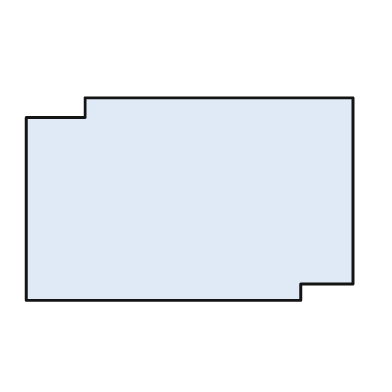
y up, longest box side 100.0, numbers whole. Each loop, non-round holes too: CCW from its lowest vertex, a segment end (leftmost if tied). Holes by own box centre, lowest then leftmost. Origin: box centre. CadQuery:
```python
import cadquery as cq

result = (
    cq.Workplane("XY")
    .moveTo(-50.0, -31.0)
    .lineTo(34.0, -31.0)
    .lineTo(34.0, -26.0)
    .lineTo(50.0, -26.0)
    .lineTo(50.0, 31.0)
    .lineTo(-32.0, 31.0)
    .lineTo(-32.0, 25.0)
    .lineTo(-50.0, 25.0)
    .close()
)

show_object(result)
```